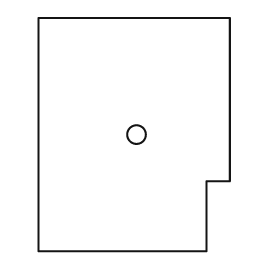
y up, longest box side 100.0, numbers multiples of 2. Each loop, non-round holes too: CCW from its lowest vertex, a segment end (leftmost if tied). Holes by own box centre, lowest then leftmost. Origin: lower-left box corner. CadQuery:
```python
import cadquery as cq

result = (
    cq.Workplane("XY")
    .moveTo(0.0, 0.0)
    .lineTo(72.0, 0.0)
    .lineTo(72.0, 30.0)
    .lineTo(82.0, 30.0)
    .lineTo(82.0, 100.0)
    .lineTo(0.0, 100.0)
    .close()
    .moveTo(42.0, 50.0)
    .circle(4.0)
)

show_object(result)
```